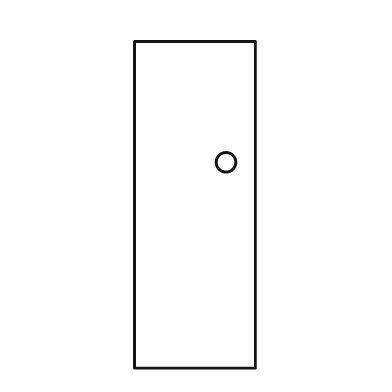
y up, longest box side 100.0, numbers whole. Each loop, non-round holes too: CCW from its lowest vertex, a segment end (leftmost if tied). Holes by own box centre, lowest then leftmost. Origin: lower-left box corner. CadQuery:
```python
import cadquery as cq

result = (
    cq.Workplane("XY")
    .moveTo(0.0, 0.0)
    .lineTo(37.0, 0.0)
    .lineTo(37.0, 100.0)
    .lineTo(0.0, 100.0)
    .close()
    .moveTo(28.0, 63.0)
    .circle(3.0)
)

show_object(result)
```